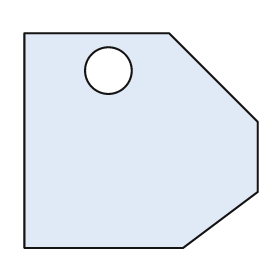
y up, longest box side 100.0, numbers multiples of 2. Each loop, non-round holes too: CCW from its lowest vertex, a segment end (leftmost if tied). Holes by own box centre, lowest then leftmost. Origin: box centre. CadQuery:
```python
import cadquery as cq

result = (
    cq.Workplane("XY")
    .moveTo(-50.0, -46.0)
    .lineTo(18.0, -46.0)
    .lineTo(50.0, -22.0)
    .lineTo(50.0, 8.0)
    .lineTo(12.0, 46.0)
    .lineTo(-50.0, 46.0)
    .close()
    .moveTo(-14.0, 30.0)
    .circle(10.0)
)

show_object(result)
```